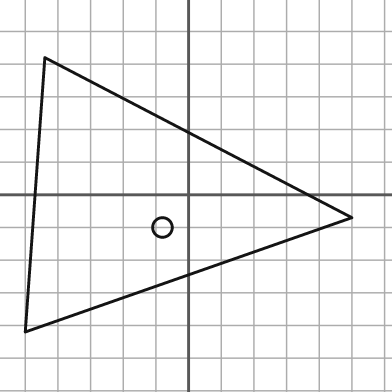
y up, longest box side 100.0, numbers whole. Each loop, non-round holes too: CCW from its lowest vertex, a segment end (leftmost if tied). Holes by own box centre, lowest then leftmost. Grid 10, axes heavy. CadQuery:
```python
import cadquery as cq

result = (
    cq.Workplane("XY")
    .moveTo(-50.0, -42.0)
    .lineTo(50.0, -7.0)
    .lineTo(-44.0, 42.0)
    .close()
    .moveTo(-8.0, -10.0)
    .circle(3.0)
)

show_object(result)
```